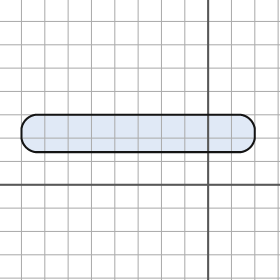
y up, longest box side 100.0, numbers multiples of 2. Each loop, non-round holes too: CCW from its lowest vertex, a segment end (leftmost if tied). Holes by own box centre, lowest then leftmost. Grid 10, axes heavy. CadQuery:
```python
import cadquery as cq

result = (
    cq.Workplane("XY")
    .moveTo(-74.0, 14.0)
    .lineTo(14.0, 14.0)
    .threePointArc((18.0, 16.0), (20.0, 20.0))
    .lineTo(20.0, 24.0)
    .threePointArc((18.0, 28.0), (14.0, 30.0))
    .lineTo(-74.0, 30.0)
    .threePointArc((-78.0, 28.0), (-80.0, 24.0))
    .lineTo(-80.0, 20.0)
    .threePointArc((-78.0, 16.0), (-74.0, 14.0))
    .close()
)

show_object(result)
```